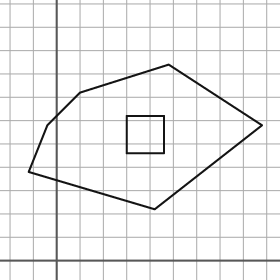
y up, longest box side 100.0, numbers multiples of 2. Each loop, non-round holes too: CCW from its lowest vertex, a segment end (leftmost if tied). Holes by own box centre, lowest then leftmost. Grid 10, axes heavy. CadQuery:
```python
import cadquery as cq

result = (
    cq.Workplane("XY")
    .moveTo(42.0, 22.0)
    .lineTo(88.0, 58.0)
    .lineTo(48.0, 84.0)
    .lineTo(10.0, 72.0)
    .lineTo(-4.0, 58.0)
    .lineTo(-12.0, 38.0)
    .close()
    .moveTo(30.0, 46.0)
    .lineTo(46.0, 46.0)
    .lineTo(46.0, 62.0)
    .lineTo(30.0, 62.0)
    .close()
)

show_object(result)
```